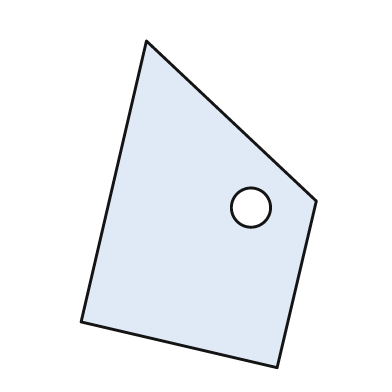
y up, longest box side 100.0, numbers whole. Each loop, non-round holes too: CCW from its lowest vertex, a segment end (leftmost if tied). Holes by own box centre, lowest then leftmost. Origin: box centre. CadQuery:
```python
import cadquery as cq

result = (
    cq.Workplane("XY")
    .moveTo(24.0, -50.0)
    .lineTo(36.0, 1.0)
    .lineTo(-16.0, 50.0)
    .lineTo(-36.0, -36.0)
    .close()
    .moveTo(16.0, -1.0)
    .circle(6.0)
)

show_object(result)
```